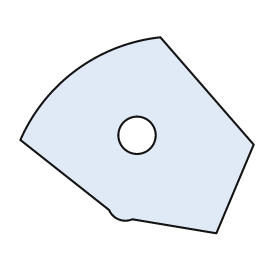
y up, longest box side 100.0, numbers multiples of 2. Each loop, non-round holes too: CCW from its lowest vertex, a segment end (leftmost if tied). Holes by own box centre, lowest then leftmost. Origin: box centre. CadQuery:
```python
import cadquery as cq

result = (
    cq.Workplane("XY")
    .moveTo(34.0, -42.0)
    .lineTo(50.0, -4.0)
    .lineTo(10.0, 42.0)
    .threePointArc((-26.0, 28.0), (-50.0, -2.0))
    .lineTo(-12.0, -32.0)
    .threePointArc((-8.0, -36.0), (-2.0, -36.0))
    .close()
    .moveTo(0.0, 0.0)
    .circle(8.0)
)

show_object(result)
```